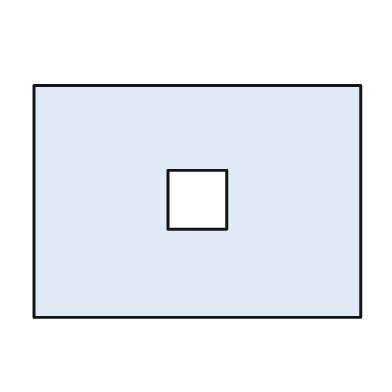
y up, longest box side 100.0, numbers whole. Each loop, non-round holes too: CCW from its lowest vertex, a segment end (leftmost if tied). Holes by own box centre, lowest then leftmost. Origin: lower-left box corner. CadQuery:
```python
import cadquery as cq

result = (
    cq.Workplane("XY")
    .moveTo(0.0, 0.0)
    .lineTo(100.0, 0.0)
    .lineTo(100.0, 71.0)
    .lineTo(0.0, 71.0)
    .close()
    .moveTo(41.0, 27.0)
    .lineTo(59.0, 27.0)
    .lineTo(59.0, 45.0)
    .lineTo(41.0, 45.0)
    .close()
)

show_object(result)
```